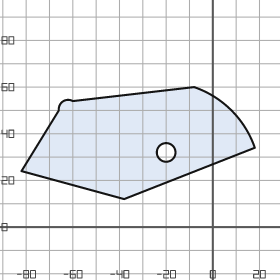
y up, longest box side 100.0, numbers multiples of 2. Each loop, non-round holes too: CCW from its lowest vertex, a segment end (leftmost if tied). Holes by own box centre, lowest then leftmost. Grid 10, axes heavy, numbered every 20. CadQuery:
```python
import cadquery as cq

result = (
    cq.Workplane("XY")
    .moveTo(-38.0, 12.0)
    .lineTo(18.0, 34.0)
    .threePointArc((8.0, 50.0), (-8.0, 60.0))
    .lineTo(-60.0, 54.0)
    .threePointArc((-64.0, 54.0), (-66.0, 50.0))
    .lineTo(-82.0, 24.0)
    .close()
    .moveTo(-20.0, 32.0)
    .circle(4.0)
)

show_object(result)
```